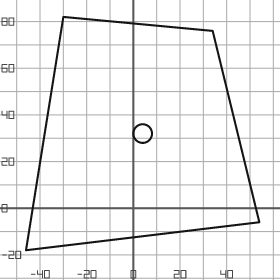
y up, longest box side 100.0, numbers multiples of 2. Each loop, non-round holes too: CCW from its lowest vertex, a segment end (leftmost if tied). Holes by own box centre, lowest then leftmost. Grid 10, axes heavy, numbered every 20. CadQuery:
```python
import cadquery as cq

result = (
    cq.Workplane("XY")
    .moveTo(-46.0, -18.0)
    .lineTo(54.0, -6.0)
    .lineTo(34.0, 76.0)
    .lineTo(-30.0, 82.0)
    .close()
    .moveTo(4.0, 32.0)
    .circle(4.0)
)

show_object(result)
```